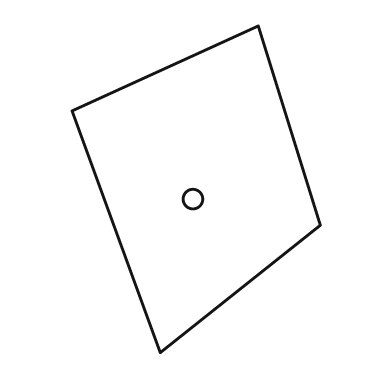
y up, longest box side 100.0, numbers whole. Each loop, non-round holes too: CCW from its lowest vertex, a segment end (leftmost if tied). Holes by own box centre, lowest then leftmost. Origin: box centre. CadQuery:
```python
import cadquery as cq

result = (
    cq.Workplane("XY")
    .moveTo(-11.0, -50.0)
    .lineTo(38.0, -11.0)
    .lineTo(19.0, 50.0)
    .lineTo(-38.0, 24.0)
    .close()
    .moveTo(-1.0, -3.0)
    .circle(3.0)
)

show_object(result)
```